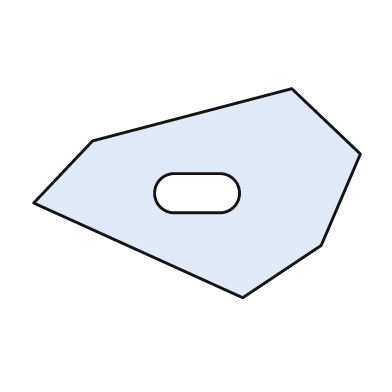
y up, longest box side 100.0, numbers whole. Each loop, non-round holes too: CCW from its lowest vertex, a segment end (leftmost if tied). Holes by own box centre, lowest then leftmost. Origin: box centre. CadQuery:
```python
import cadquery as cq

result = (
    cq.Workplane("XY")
    .moveTo(14.0, -32.0)
    .lineTo(38.0, -16.0)
    .lineTo(50.0, 12.0)
    .lineTo(29.0, 32.0)
    .lineTo(-32.0, 16.0)
    .lineTo(-50.0, -3.0)
    .close()
    .moveTo(-7.0, -6.0)
    .lineTo(7.0, -6.0)
    .threePointArc((13.0, 0.0), (7.0, 6.0))
    .lineTo(-7.0, 6.0)
    .threePointArc((-13.0, 0.0), (-7.0, -6.0))
    .close()
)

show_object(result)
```